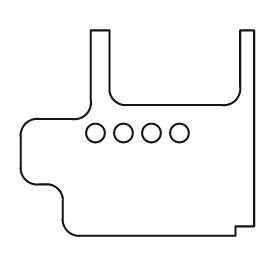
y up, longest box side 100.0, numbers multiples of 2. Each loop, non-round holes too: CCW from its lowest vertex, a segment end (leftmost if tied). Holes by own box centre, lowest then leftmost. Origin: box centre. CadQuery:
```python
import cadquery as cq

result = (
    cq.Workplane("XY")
    .moveTo(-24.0, -44.0)
    .lineTo(42.0, -44.0)
    .lineTo(42.0, -40.0)
    .lineTo(50.0, -40.0)
    .lineTo(50.0, 44.0)
    .lineTo(44.0, 44.0)
    .lineTo(44.0, 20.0)
    .threePointArc((42.0, 14.0), (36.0, 12.0))
    .lineTo(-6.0, 12.0)
    .threePointArc((-10.0, 14.0), (-12.0, 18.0))
    .lineTo(-12.0, 44.0)
    .lineTo(-20.0, 44.0)
    .lineTo(-20.0, 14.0)
    .threePointArc((-22.0, 8.0), (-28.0, 6.0))
    .lineTo(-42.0, 6.0)
    .threePointArc((-48.0, 4.0), (-50.0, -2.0))
    .lineTo(-50.0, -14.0)
    .threePointArc((-48.0, -20.0), (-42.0, -22.0))
    .lineTo(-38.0, -22.0)
    .threePointArc((-34.0, -24.0), (-32.0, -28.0))
    .lineTo(-32.0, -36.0)
    .threePointArc((-30.0, -42.0), (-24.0, -44.0))
    .close()
    .moveTo(-18.0, 0.0)
    .circle(4.0)
    .moveTo(-6.0, 0.0)
    .circle(4.0)
    .moveTo(6.0, 0.0)
    .circle(4.0)
    .moveTo(18.0, 0.0)
    .circle(4.0)
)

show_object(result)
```